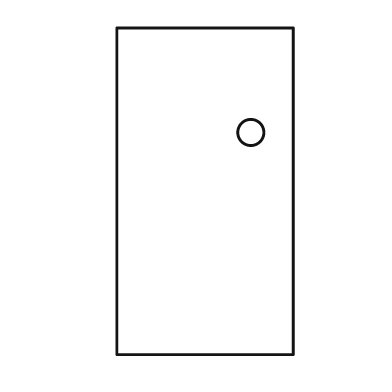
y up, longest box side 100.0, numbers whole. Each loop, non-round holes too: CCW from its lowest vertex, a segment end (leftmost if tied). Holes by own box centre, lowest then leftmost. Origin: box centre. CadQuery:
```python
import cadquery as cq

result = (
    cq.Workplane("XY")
    .moveTo(-27.0, -50.0)
    .lineTo(27.0, -50.0)
    .lineTo(27.0, 50.0)
    .lineTo(-27.0, 50.0)
    .close()
    .moveTo(14.0, 18.0)
    .circle(4.0)
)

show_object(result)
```